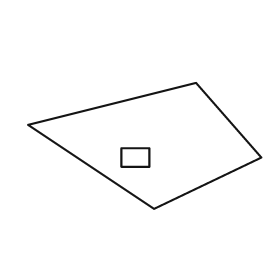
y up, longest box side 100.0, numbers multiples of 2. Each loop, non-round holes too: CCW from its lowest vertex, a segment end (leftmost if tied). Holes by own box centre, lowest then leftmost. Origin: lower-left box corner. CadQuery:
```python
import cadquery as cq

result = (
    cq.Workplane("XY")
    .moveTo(54.0, 0.0)
    .lineTo(100.0, 22.0)
    .lineTo(72.0, 54.0)
    .lineTo(0.0, 36.0)
    .close()
    .moveTo(40.0, 18.0)
    .lineTo(52.0, 18.0)
    .lineTo(52.0, 26.0)
    .lineTo(40.0, 26.0)
    .close()
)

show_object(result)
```